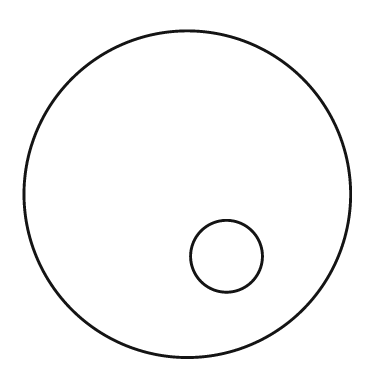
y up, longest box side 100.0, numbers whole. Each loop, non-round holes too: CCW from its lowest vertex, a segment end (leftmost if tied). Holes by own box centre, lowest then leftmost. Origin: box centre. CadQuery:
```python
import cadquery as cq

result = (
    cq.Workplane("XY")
    .moveTo(0.0, 0.0)
    .circle(50.0)
    .moveTo(12.0, -19.0)
    .circle(11.0)
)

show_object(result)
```